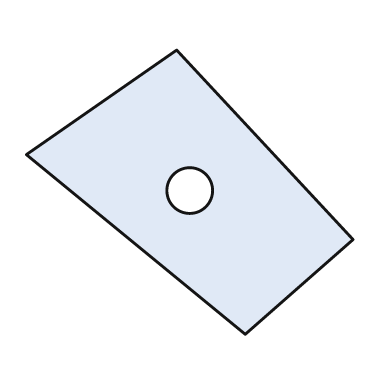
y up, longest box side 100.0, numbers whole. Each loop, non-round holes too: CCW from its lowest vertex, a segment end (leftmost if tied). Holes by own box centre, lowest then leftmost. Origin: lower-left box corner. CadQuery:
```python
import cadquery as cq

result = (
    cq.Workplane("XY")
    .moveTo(67.0, 0.0)
    .lineTo(100.0, 29.0)
    .lineTo(46.0, 87.0)
    .lineTo(0.0, 55.0)
    .close()
    .moveTo(50.0, 44.0)
    .circle(7.0)
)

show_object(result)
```